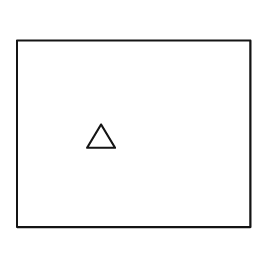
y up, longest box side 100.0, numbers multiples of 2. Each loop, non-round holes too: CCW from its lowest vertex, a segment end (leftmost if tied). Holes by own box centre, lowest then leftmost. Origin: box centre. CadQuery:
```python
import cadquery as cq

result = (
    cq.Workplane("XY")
    .moveTo(-50.0, -40.0)
    .lineTo(50.0, -40.0)
    .lineTo(50.0, 40.0)
    .lineTo(-50.0, 40.0)
    .close()
    .moveTo(-20.0, -6.0)
    .lineTo(-8.0, -6.0)
    .lineTo(-14.0, 4.0)
    .close()
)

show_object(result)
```